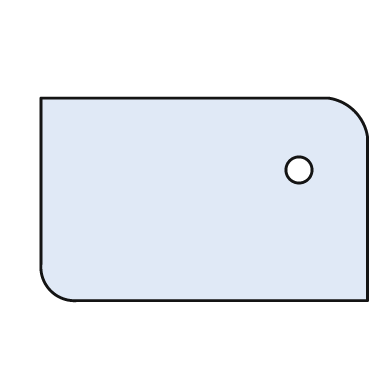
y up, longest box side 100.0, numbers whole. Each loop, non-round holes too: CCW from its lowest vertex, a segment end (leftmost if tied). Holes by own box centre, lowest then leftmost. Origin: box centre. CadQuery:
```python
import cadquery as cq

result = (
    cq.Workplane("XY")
    .moveTo(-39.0, -31.0)
    .lineTo(50.0, -31.0)
    .lineTo(50.0, 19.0)
    .threePointArc((46.0, 27.0), (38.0, 31.0))
    .lineTo(-50.0, 31.0)
    .lineTo(-50.0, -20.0)
    .threePointArc((-47.0, -28.0), (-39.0, -31.0))
    .close()
    .moveTo(29.0, 9.0)
    .circle(4.0)
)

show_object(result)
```